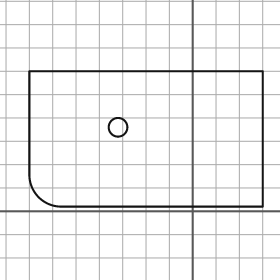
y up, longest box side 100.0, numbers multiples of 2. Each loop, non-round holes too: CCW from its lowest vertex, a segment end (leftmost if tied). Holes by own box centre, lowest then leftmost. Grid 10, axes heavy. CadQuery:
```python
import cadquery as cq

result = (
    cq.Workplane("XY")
    .moveTo(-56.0, 2.0)
    .lineTo(30.0, 2.0)
    .lineTo(30.0, 60.0)
    .lineTo(-70.0, 60.0)
    .lineTo(-70.0, 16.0)
    .threePointArc((-66.0, 6.0), (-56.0, 2.0))
    .close()
    .moveTo(-32.0, 36.0)
    .circle(4.0)
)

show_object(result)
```